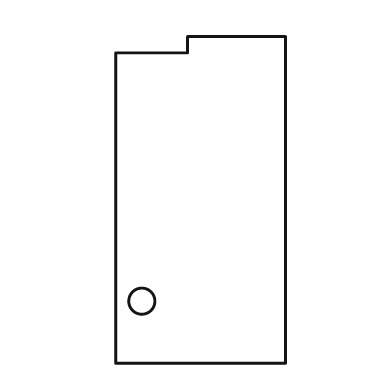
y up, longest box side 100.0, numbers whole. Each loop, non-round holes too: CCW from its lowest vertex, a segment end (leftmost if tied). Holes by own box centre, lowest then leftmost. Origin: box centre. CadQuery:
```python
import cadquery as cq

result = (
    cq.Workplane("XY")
    .moveTo(-26.0, -50.0)
    .lineTo(26.0, -50.0)
    .lineTo(26.0, 50.0)
    .lineTo(-4.0, 50.0)
    .lineTo(-4.0, 45.0)
    .lineTo(-26.0, 45.0)
    .close()
    .moveTo(-18.0, -31.0)
    .circle(4.0)
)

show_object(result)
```